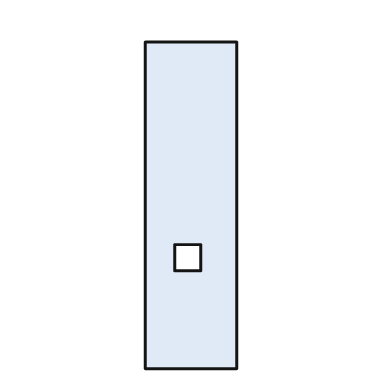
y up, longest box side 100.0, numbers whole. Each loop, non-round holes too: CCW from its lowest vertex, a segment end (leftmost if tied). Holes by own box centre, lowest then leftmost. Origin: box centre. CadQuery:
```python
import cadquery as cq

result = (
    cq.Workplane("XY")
    .moveTo(-14.0, -50.0)
    .lineTo(14.0, -50.0)
    .lineTo(14.0, 50.0)
    .lineTo(-14.0, 50.0)
    .close()
    .moveTo(-5.0, -20.0)
    .lineTo(3.0, -20.0)
    .lineTo(3.0, -12.0)
    .lineTo(-5.0, -12.0)
    .close()
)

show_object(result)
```